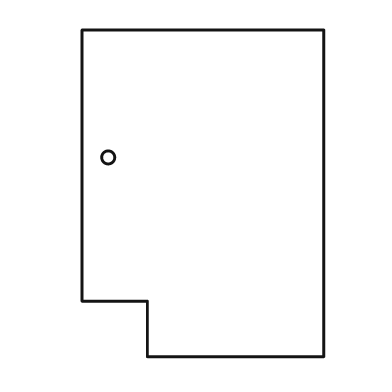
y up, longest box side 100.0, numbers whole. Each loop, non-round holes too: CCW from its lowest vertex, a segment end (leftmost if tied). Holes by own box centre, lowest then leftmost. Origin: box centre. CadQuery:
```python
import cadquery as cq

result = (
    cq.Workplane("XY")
    .moveTo(-17.0, -50.0)
    .lineTo(37.0, -50.0)
    .lineTo(37.0, 50.0)
    .lineTo(-37.0, 50.0)
    .lineTo(-37.0, -33.0)
    .lineTo(-17.0, -33.0)
    .close()
    .moveTo(-29.0, 11.0)
    .circle(2.0)
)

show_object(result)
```